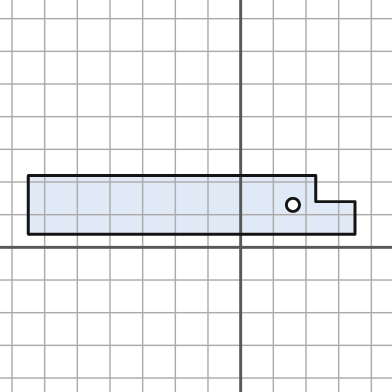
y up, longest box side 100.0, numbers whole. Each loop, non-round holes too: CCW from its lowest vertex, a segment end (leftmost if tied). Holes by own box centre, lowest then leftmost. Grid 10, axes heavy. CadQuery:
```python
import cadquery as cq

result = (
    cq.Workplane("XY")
    .moveTo(-65.0, 4.0)
    .lineTo(35.0, 4.0)
    .lineTo(35.0, 14.0)
    .lineTo(23.0, 14.0)
    .lineTo(23.0, 22.0)
    .lineTo(-65.0, 22.0)
    .close()
    .moveTo(16.0, 13.0)
    .circle(2.0)
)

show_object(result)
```